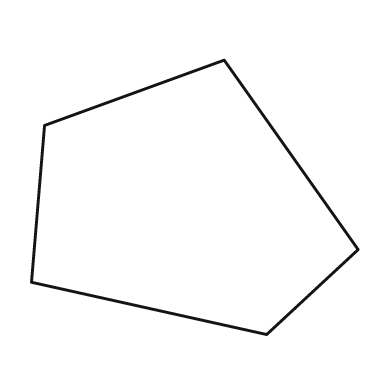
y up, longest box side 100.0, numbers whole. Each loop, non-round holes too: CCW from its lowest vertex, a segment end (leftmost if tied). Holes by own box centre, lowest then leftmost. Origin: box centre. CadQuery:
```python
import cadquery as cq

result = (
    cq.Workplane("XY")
    .moveTo(22.0, -42.0)
    .lineTo(50.0, -16.0)
    .lineTo(9.0, 42.0)
    .lineTo(-46.0, 22.0)
    .lineTo(-50.0, -26.0)
    .close()
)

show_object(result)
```